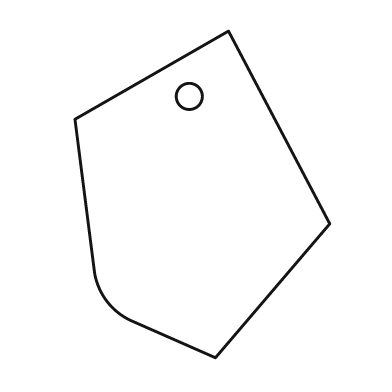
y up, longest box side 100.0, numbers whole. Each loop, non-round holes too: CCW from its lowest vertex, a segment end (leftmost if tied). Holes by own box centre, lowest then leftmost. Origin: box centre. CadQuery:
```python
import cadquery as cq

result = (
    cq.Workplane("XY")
    .moveTo(4.0, -50.0)
    .lineTo(39.0, -9.0)
    .lineTo(8.0, 50.0)
    .lineTo(-39.0, 23.0)
    .lineTo(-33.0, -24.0)
    .threePointArc((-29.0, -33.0), (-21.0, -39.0))
    .close()
    .moveTo(-4.0, 30.0)
    .circle(4.0)
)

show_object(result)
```